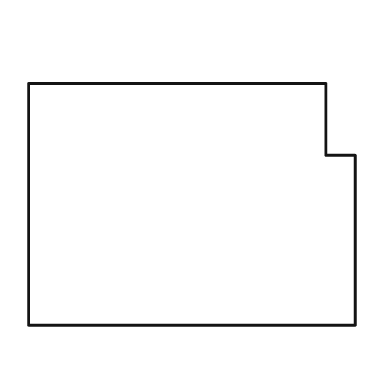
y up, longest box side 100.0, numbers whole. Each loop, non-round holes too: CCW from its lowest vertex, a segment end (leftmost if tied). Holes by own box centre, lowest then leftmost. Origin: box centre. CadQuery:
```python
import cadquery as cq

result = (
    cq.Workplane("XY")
    .moveTo(-50.0, -37.0)
    .lineTo(50.0, -37.0)
    .lineTo(50.0, 15.0)
    .lineTo(41.0, 15.0)
    .lineTo(41.0, 37.0)
    .lineTo(-50.0, 37.0)
    .close()
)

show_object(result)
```